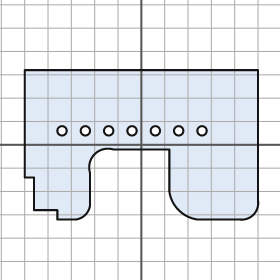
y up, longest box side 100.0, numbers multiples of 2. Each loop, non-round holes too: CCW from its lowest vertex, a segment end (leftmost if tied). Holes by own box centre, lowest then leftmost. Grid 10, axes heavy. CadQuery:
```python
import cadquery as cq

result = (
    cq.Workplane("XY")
    .moveTo(-36.0, -32.0)
    .lineTo(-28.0, -32.0)
    .threePointArc((-24.0, -30.0), (-22.0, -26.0))
    .lineTo(-22.0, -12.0)
    .threePointArc((-20.0, -4.0), (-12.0, -2.0))
    .lineTo(12.0, -2.0)
    .lineTo(12.0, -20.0)
    .threePointArc((16.0, -28.0), (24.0, -32.0))
    .lineTo(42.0, -32.0)
    .threePointArc((48.0, -30.0), (50.0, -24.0))
    .lineTo(50.0, 32.0)
    .lineTo(-50.0, 32.0)
    .lineTo(-50.0, -14.0)
    .lineTo(-46.0, -14.0)
    .lineTo(-46.0, -28.0)
    .lineTo(-36.0, -28.0)
    .close()
    .moveTo(-34.0, 6.0)
    .circle(2.0)
    .moveTo(-24.0, 6.0)
    .circle(2.0)
    .moveTo(-14.0, 6.0)
    .circle(2.0)
    .moveTo(-4.0, 6.0)
    .circle(2.0)
    .moveTo(6.0, 6.0)
    .circle(2.0)
    .moveTo(16.0, 6.0)
    .circle(2.0)
    .moveTo(26.0, 6.0)
    .circle(2.0)
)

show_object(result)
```